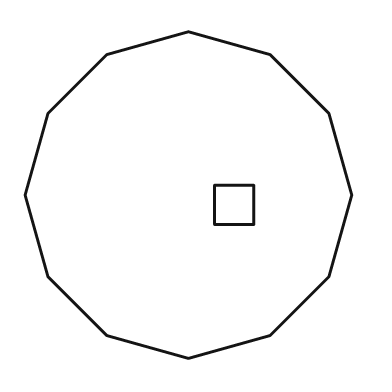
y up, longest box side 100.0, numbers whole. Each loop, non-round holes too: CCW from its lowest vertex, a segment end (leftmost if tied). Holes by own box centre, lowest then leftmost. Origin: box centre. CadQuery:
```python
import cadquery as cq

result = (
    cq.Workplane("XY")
    .moveTo(0.0, -50.0)
    .lineTo(25.0, -43.0)
    .lineTo(43.0, -25.0)
    .lineTo(50.0, 0.0)
    .lineTo(43.0, 25.0)
    .lineTo(25.0, 43.0)
    .lineTo(0.0, 50.0)
    .lineTo(-25.0, 43.0)
    .lineTo(-43.0, 25.0)
    .lineTo(-50.0, 0.0)
    .lineTo(-43.0, -25.0)
    .lineTo(-25.0, -43.0)
    .close()
    .moveTo(8.0, -9.0)
    .lineTo(20.0, -9.0)
    .lineTo(20.0, 3.0)
    .lineTo(8.0, 3.0)
    .close()
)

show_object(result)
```